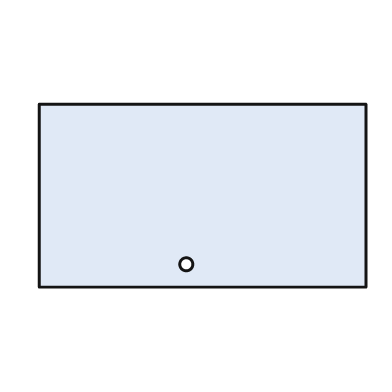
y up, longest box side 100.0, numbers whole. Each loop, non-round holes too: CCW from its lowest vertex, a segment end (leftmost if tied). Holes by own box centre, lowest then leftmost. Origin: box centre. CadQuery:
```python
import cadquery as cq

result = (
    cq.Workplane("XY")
    .moveTo(-50.0, -28.0)
    .lineTo(50.0, -28.0)
    .lineTo(50.0, 28.0)
    .lineTo(-50.0, 28.0)
    .close()
    .moveTo(-5.0, -21.0)
    .circle(2.0)
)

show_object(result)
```